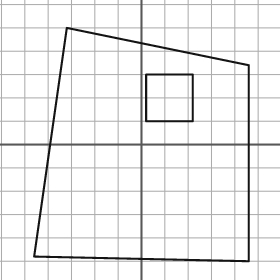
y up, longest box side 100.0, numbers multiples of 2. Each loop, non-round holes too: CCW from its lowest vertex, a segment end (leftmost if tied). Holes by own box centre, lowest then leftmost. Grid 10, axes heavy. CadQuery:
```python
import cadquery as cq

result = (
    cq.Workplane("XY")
    .moveTo(46.0, -50.0)
    .lineTo(46.0, 34.0)
    .lineTo(-32.0, 50.0)
    .lineTo(-46.0, -48.0)
    .close()
    .moveTo(2.0, 10.0)
    .lineTo(22.0, 10.0)
    .lineTo(22.0, 30.0)
    .lineTo(2.0, 30.0)
    .close()
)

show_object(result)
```